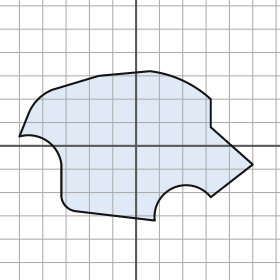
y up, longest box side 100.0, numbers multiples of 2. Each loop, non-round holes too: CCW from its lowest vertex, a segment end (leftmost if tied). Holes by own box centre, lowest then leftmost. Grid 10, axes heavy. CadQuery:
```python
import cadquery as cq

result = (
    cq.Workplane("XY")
    .moveTo(8.0, -32.0)
    .threePointArc((16.0, -18.0), (32.0, -22.0))
    .lineTo(50.0, -8.0)
    .lineTo(32.0, 8.0)
    .lineTo(32.0, 20.0)
    .threePointArc((20.0, 28.0), (6.0, 32.0))
    .lineTo(-16.0, 30.0)
    .lineTo(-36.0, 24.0)
    .threePointArc((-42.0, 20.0), (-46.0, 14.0))
    .lineTo(-50.0, 4.0)
    .threePointArc((-38.0, 2.0), (-32.0, -8.0))
    .lineTo(-32.0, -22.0)
    .threePointArc((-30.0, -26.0), (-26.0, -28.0))
    .close()
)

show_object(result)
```